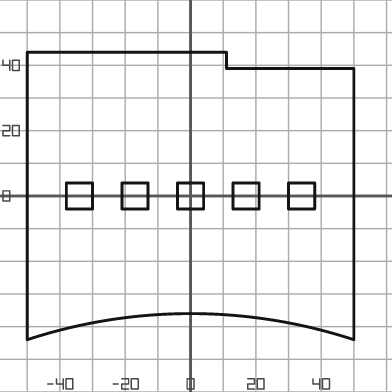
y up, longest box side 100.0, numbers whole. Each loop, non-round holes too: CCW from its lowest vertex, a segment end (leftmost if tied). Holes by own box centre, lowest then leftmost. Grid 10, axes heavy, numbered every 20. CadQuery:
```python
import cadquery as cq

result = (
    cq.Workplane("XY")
    .moveTo(-50.0, -44.0)
    .threePointArc((0.0, -36.0), (50.0, -44.0))
    .lineTo(50.0, 39.0)
    .lineTo(11.0, 39.0)
    .lineTo(11.0, 44.0)
    .lineTo(-50.0, 44.0)
    .close()
    .moveTo(-38.0, -4.0)
    .lineTo(-30.0, -4.0)
    .lineTo(-30.0, 4.0)
    .lineTo(-38.0, 4.0)
    .close()
    .moveTo(-21.0, -4.0)
    .lineTo(-13.0, -4.0)
    .lineTo(-13.0, 4.0)
    .lineTo(-21.0, 4.0)
    .close()
    .moveTo(-4.0, -4.0)
    .lineTo(4.0, -4.0)
    .lineTo(4.0, 4.0)
    .lineTo(-4.0, 4.0)
    .close()
    .moveTo(13.0, -4.0)
    .lineTo(21.0, -4.0)
    .lineTo(21.0, 4.0)
    .lineTo(13.0, 4.0)
    .close()
    .moveTo(30.0, -4.0)
    .lineTo(38.0, -4.0)
    .lineTo(38.0, 4.0)
    .lineTo(30.0, 4.0)
    .close()
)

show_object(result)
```